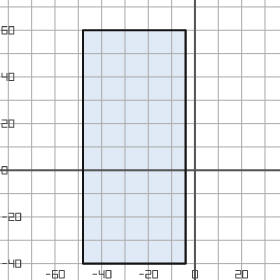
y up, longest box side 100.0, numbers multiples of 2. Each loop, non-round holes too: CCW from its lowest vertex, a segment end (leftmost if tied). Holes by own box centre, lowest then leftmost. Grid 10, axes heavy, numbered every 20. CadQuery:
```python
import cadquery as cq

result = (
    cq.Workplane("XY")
    .moveTo(-48.0, -40.0)
    .lineTo(-4.0, -40.0)
    .lineTo(-4.0, 60.0)
    .lineTo(-48.0, 60.0)
    .close()
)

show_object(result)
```